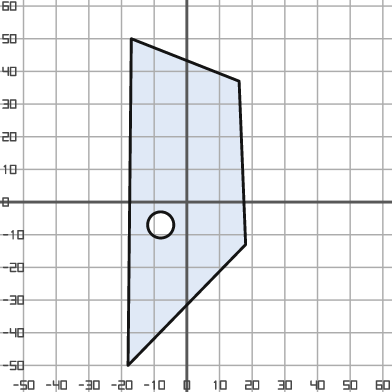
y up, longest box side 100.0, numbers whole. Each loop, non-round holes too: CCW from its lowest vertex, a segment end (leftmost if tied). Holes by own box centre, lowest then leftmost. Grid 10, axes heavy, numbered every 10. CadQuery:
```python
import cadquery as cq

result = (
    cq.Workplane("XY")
    .moveTo(-18.0, -50.0)
    .lineTo(18.0, -13.0)
    .lineTo(16.0, 37.0)
    .lineTo(-17.0, 50.0)
    .close()
    .moveTo(-8.0, -7.0)
    .circle(4.0)
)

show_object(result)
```